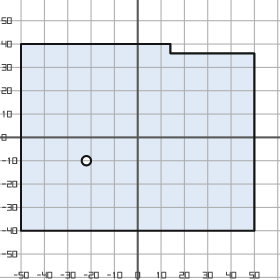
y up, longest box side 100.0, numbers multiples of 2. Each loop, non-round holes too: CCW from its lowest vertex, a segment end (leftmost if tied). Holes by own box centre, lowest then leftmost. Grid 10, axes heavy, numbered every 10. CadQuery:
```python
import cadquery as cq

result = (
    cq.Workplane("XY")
    .moveTo(-50.0, -40.0)
    .lineTo(50.0, -40.0)
    .lineTo(50.0, 36.0)
    .lineTo(14.0, 36.0)
    .lineTo(14.0, 40.0)
    .lineTo(-50.0, 40.0)
    .close()
    .moveTo(-22.0, -10.0)
    .circle(2.0)
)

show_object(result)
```